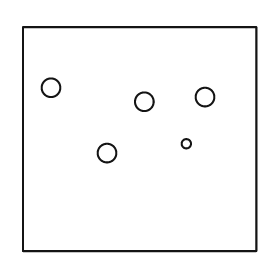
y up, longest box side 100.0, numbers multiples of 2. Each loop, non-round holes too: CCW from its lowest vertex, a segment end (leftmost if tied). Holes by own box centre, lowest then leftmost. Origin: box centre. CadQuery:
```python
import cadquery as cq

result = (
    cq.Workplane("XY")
    .moveTo(-50.0, -48.0)
    .lineTo(50.0, -48.0)
    .lineTo(50.0, 48.0)
    .lineTo(-50.0, 48.0)
    .close()
    .moveTo(-14.0, -6.0)
    .circle(4.0)
    .moveTo(20.0, -2.0)
    .circle(2.0)
    .moveTo(2.0, 16.0)
    .circle(4.0)
    .moveTo(28.0, 18.0)
    .circle(4.0)
    .moveTo(-38.0, 22.0)
    .circle(4.0)
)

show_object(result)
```